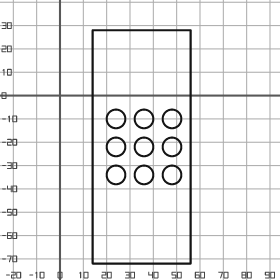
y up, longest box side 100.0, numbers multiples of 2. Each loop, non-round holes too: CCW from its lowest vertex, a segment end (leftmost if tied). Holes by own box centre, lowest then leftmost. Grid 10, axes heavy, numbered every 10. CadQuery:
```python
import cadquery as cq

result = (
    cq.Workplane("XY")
    .moveTo(14.0, -72.0)
    .lineTo(56.0, -72.0)
    .lineTo(56.0, 28.0)
    .lineTo(14.0, 28.0)
    .close()
    .moveTo(24.0, -34.0)
    .circle(4.0)
    .moveTo(36.0, -34.0)
    .circle(4.0)
    .moveTo(48.0, -34.0)
    .circle(4.0)
    .moveTo(24.0, -22.0)
    .circle(4.0)
    .moveTo(36.0, -22.0)
    .circle(4.0)
    .moveTo(48.0, -22.0)
    .circle(4.0)
    .moveTo(24.0, -10.0)
    .circle(4.0)
    .moveTo(36.0, -10.0)
    .circle(4.0)
    .moveTo(48.0, -10.0)
    .circle(4.0)
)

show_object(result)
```